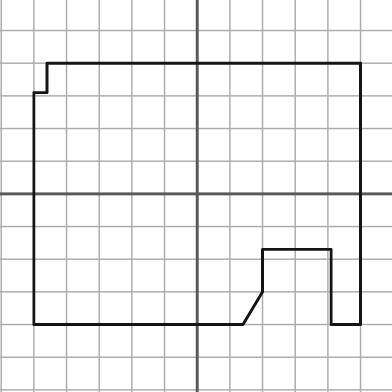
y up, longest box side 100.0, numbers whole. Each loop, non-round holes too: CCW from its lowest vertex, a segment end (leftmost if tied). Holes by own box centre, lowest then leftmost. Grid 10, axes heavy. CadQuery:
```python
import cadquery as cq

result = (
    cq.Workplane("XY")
    .moveTo(-50.0, -40.0)
    .lineTo(14.0, -40.0)
    .lineTo(20.0, -30.0)
    .lineTo(20.0, -17.0)
    .lineTo(41.0, -17.0)
    .lineTo(41.0, -40.0)
    .lineTo(50.0, -40.0)
    .lineTo(50.0, 40.0)
    .lineTo(-46.0, 40.0)
    .lineTo(-46.0, 31.0)
    .lineTo(-50.0, 31.0)
    .close()
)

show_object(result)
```